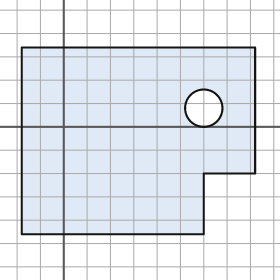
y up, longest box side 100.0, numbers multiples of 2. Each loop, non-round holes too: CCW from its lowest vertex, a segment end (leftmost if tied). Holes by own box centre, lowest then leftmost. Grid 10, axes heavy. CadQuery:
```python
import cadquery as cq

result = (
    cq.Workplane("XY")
    .moveTo(-18.0, -46.0)
    .lineTo(60.0, -46.0)
    .lineTo(60.0, -20.0)
    .lineTo(82.0, -20.0)
    .lineTo(82.0, 34.0)
    .lineTo(-18.0, 34.0)
    .close()
    .moveTo(60.0, 8.0)
    .circle(8.0)
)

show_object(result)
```